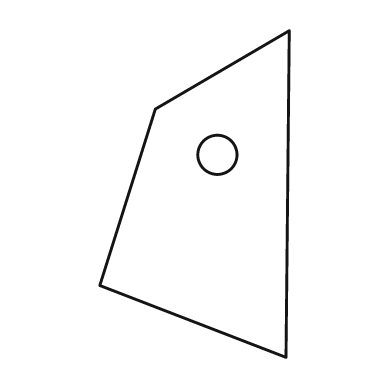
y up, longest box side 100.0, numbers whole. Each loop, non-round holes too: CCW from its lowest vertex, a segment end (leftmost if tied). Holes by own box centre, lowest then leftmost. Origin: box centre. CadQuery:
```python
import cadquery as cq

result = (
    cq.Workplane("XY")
    .moveTo(28.0, -50.0)
    .lineTo(29.0, 50.0)
    .lineTo(-12.0, 26.0)
    .lineTo(-29.0, -28.0)
    .close()
    .moveTo(7.0, 12.0)
    .circle(6.0)
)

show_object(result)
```